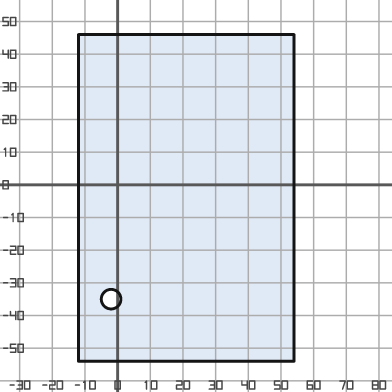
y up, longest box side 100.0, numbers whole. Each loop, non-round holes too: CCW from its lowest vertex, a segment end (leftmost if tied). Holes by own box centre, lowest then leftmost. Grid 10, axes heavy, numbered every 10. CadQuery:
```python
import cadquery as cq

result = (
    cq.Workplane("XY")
    .moveTo(-12.0, -54.0)
    .lineTo(54.0, -54.0)
    .lineTo(54.0, 46.0)
    .lineTo(-12.0, 46.0)
    .close()
    .moveTo(-2.0, -35.0)
    .circle(3.0)
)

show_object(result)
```